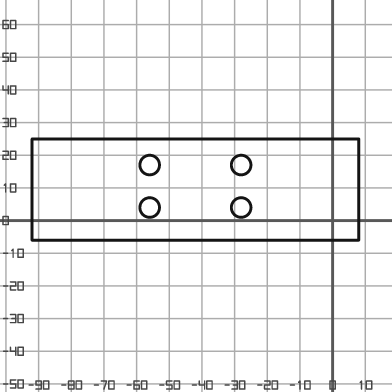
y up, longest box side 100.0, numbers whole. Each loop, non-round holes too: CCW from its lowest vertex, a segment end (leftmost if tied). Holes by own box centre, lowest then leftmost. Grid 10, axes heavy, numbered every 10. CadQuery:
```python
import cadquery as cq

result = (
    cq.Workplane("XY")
    .moveTo(-92.0, -6.0)
    .lineTo(8.0, -6.0)
    .lineTo(8.0, 25.0)
    .lineTo(-92.0, 25.0)
    .close()
    .moveTo(-56.0, 4.0)
    .circle(3.0)
    .moveTo(-28.0, 4.0)
    .circle(3.0)
    .moveTo(-56.0, 17.0)
    .circle(3.0)
    .moveTo(-28.0, 17.0)
    .circle(3.0)
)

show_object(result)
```